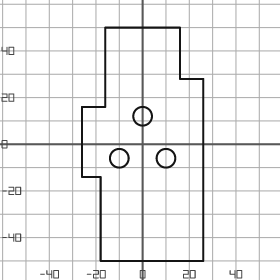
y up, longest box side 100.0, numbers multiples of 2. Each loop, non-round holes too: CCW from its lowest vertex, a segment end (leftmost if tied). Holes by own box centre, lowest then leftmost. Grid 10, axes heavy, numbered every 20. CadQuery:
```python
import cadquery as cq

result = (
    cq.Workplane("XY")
    .moveTo(-18.0, -50.0)
    .lineTo(26.0, -50.0)
    .lineTo(26.0, 28.0)
    .lineTo(16.0, 28.0)
    .lineTo(16.0, 50.0)
    .lineTo(-16.0, 50.0)
    .lineTo(-16.0, 16.0)
    .lineTo(-26.0, 16.0)
    .lineTo(-26.0, -14.0)
    .lineTo(-18.0, -14.0)
    .close()
    .moveTo(-10.0, -6.0)
    .circle(4.0)
    .moveTo(10.0, -6.0)
    .circle(4.0)
    .moveTo(0.0, 12.0)
    .circle(4.0)
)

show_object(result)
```